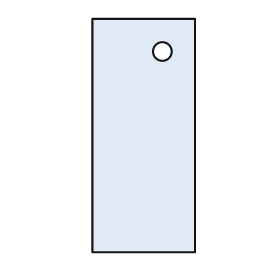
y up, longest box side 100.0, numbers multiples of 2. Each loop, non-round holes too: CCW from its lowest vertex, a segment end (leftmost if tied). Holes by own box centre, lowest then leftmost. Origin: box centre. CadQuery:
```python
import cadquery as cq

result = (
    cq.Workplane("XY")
    .moveTo(-22.0, -50.0)
    .lineTo(22.0, -50.0)
    .lineTo(22.0, 50.0)
    .lineTo(-22.0, 50.0)
    .close()
    .moveTo(8.0, 36.0)
    .circle(4.0)
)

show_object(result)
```